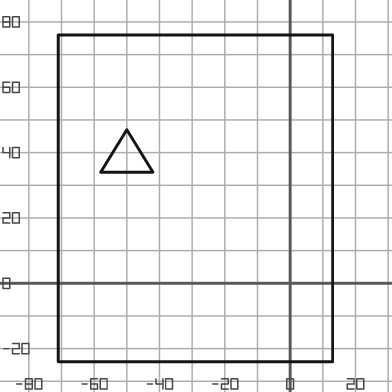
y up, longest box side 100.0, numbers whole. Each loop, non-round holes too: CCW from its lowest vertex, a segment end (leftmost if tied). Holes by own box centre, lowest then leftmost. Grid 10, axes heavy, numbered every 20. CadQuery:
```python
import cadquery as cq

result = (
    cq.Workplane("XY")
    .moveTo(-71.0, -24.0)
    .lineTo(13.0, -24.0)
    .lineTo(13.0, 76.0)
    .lineTo(-71.0, 76.0)
    .close()
    .moveTo(-58.0, 34.0)
    .lineTo(-42.0, 34.0)
    .lineTo(-50.0, 47.0)
    .close()
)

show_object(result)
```